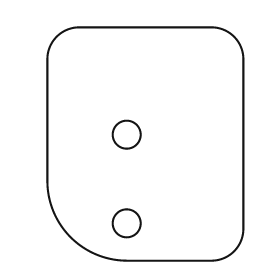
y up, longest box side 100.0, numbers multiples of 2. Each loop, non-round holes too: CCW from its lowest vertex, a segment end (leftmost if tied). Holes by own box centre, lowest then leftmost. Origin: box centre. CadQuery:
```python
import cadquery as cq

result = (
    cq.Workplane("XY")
    .moveTo(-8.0, -50.0)
    .lineTo(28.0, -50.0)
    .threePointArc((38.0, -46.0), (42.0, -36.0))
    .lineTo(42.0, 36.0)
    .threePointArc((38.0, 46.0), (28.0, 50.0))
    .lineTo(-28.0, 50.0)
    .threePointArc((-38.0, 46.0), (-42.0, 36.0))
    .lineTo(-42.0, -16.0)
    .threePointArc((-32.0, -40.0), (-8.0, -50.0))
    .close()
    .moveTo(-8.0, -34.0)
    .circle(6.0)
    .moveTo(-8.0, 4.0)
    .circle(6.0)
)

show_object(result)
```